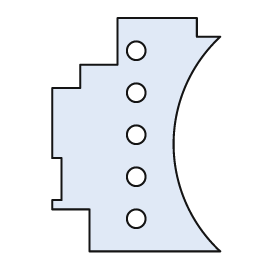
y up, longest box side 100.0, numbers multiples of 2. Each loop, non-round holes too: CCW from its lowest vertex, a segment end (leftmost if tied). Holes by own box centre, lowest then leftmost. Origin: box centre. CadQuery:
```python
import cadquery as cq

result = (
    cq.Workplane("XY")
    .moveTo(-20.0, -50.0)
    .lineTo(36.0, -50.0)
    .threePointArc((16.0, -4.0), (36.0, 42.0))
    .lineTo(26.0, 42.0)
    .lineTo(26.0, 50.0)
    .lineTo(-8.0, 50.0)
    .lineTo(-8.0, 30.0)
    .lineTo(-24.0, 30.0)
    .lineTo(-24.0, 20.0)
    .lineTo(-36.0, 20.0)
    .lineTo(-36.0, -10.0)
    .lineTo(-32.0, -10.0)
    .lineTo(-32.0, -28.0)
    .lineTo(-36.0, -28.0)
    .lineTo(-36.0, -32.0)
    .lineTo(-20.0, -32.0)
    .close()
    .moveTo(0.0, -36.0)
    .circle(4.0)
    .moveTo(0.0, -18.0)
    .circle(4.0)
    .moveTo(0.0, 0.0)
    .circle(4.0)
    .moveTo(0.0, 18.0)
    .circle(4.0)
    .moveTo(0.0, 36.0)
    .circle(4.0)
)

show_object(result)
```